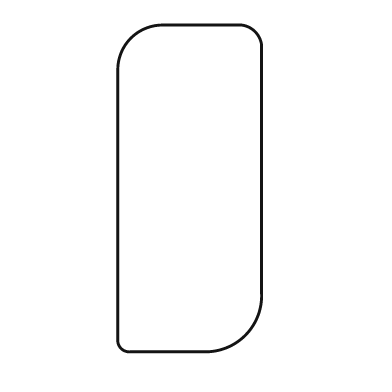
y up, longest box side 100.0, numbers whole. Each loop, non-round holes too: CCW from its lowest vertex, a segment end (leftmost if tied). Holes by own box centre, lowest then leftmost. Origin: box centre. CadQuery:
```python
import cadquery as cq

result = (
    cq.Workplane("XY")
    .moveTo(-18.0, -50.0)
    .lineTo(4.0, -50.0)
    .threePointArc((17.0, -45.0), (22.0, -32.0))
    .lineTo(22.0, 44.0)
    .threePointArc((20.0, 48.0), (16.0, 50.0))
    .lineTo(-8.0, 50.0)
    .threePointArc((-18.0, 46.0), (-22.0, 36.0))
    .lineTo(-22.0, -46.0)
    .threePointArc((-21.0, -49.0), (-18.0, -50.0))
    .close()
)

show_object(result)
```